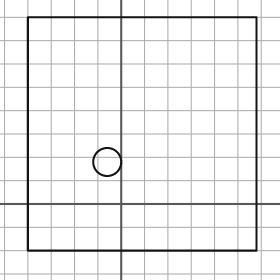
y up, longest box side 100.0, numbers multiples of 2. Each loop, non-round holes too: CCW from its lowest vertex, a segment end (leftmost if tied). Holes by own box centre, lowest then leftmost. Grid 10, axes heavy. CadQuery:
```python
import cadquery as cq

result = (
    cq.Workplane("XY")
    .moveTo(-40.0, -20.0)
    .lineTo(58.0, -20.0)
    .lineTo(58.0, 80.0)
    .lineTo(-40.0, 80.0)
    .close()
    .moveTo(-6.0, 18.0)
    .circle(6.0)
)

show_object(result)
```